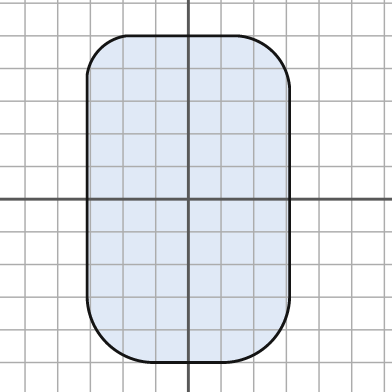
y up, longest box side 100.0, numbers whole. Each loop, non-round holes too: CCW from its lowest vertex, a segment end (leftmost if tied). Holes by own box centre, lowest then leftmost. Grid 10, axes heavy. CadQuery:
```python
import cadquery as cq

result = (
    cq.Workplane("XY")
    .moveTo(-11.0, -50.0)
    .lineTo(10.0, -50.0)
    .threePointArc((25.0, -44.0), (31.0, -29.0))
    .lineTo(31.0, 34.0)
    .threePointArc((26.0, 45.0), (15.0, 50.0))
    .lineTo(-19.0, 50.0)
    .threePointArc((-27.0, 46.0), (-31.0, 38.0))
    .lineTo(-31.0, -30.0)
    .threePointArc((-25.0, -44.0), (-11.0, -50.0))
    .close()
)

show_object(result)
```